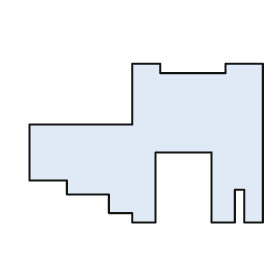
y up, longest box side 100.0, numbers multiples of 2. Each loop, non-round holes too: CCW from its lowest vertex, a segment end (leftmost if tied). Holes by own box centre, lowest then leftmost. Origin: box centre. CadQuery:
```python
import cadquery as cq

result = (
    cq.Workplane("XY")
    .moveTo(-6.0, -34.0)
    .lineTo(4.0, -34.0)
    .lineTo(4.0, -4.0)
    .lineTo(28.0, -4.0)
    .lineTo(28.0, -34.0)
    .lineTo(38.0, -34.0)
    .lineTo(38.0, -20.0)
    .lineTo(42.0, -20.0)
    .lineTo(42.0, -34.0)
    .lineTo(50.0, -34.0)
    .lineTo(50.0, 34.0)
    .lineTo(34.0, 34.0)
    .lineTo(34.0, 30.0)
    .lineTo(6.0, 30.0)
    .lineTo(6.0, 34.0)
    .lineTo(-6.0, 34.0)
    .lineTo(-6.0, 8.0)
    .lineTo(-50.0, 8.0)
    .lineTo(-50.0, -16.0)
    .lineTo(-34.0, -16.0)
    .lineTo(-34.0, -22.0)
    .lineTo(-16.0, -22.0)
    .lineTo(-16.0, -30.0)
    .lineTo(-6.0, -30.0)
    .close()
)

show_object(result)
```